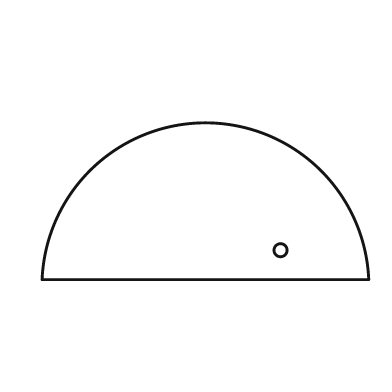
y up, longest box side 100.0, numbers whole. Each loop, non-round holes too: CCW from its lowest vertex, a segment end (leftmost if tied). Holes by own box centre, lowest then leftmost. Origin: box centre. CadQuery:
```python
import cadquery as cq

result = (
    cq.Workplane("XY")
    .moveTo(-50.0, -24.0)
    .lineTo(50.0, -24.0)
    .threePointArc((0.0, 24.0), (-50.0, -24.0))
    .close()
    .moveTo(23.0, -15.0)
    .circle(2.0)
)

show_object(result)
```